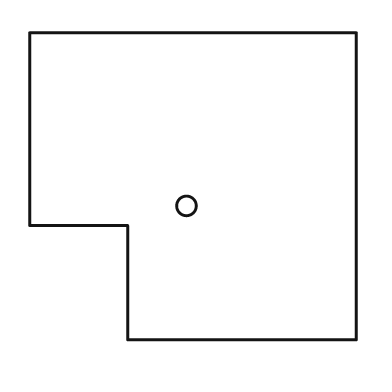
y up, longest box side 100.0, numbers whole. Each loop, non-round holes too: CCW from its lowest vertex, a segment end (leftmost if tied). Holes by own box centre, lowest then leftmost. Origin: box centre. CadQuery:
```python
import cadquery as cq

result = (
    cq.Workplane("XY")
    .moveTo(-20.0, -47.0)
    .lineTo(50.0, -47.0)
    .lineTo(50.0, 47.0)
    .lineTo(-50.0, 47.0)
    .lineTo(-50.0, -12.0)
    .lineTo(-20.0, -12.0)
    .close()
    .moveTo(-2.0, -6.0)
    .circle(3.0)
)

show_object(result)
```